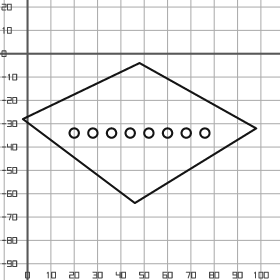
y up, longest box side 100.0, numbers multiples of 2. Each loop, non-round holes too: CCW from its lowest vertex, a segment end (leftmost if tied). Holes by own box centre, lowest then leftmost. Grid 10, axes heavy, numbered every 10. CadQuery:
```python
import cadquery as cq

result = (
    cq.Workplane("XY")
    .moveTo(46.0, -64.0)
    .lineTo(98.0, -32.0)
    .lineTo(48.0, -4.0)
    .lineTo(-2.0, -28.0)
    .close()
    .moveTo(20.0, -34.0)
    .circle(2.0)
    .moveTo(28.0, -34.0)
    .circle(2.0)
    .moveTo(36.0, -34.0)
    .circle(2.0)
    .moveTo(44.0, -34.0)
    .circle(2.0)
    .moveTo(52.0, -34.0)
    .circle(2.0)
    .moveTo(60.0, -34.0)
    .circle(2.0)
    .moveTo(68.0, -34.0)
    .circle(2.0)
    .moveTo(76.0, -34.0)
    .circle(2.0)
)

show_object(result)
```